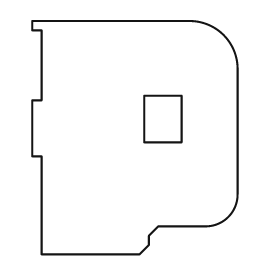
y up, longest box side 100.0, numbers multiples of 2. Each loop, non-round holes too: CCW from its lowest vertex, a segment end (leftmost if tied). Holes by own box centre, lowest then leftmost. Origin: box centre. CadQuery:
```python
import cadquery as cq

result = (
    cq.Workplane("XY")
    .moveTo(-40.0, -50.0)
    .lineTo(2.0, -50.0)
    .lineTo(6.0, -46.0)
    .lineTo(6.0, -42.0)
    .lineTo(10.0, -38.0)
    .lineTo(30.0, -38.0)
    .threePointArc((40.0, -34.0), (44.0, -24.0))
    .lineTo(44.0, 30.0)
    .threePointArc((38.0, 44.0), (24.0, 50.0))
    .lineTo(-44.0, 50.0)
    .lineTo(-44.0, 46.0)
    .lineTo(-40.0, 46.0)
    .lineTo(-40.0, 16.0)
    .lineTo(-44.0, 16.0)
    .lineTo(-44.0, -8.0)
    .lineTo(-40.0, -8.0)
    .close()
    .moveTo(4.0, -2.0)
    .lineTo(20.0, -2.0)
    .lineTo(20.0, 18.0)
    .lineTo(4.0, 18.0)
    .close()
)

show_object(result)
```